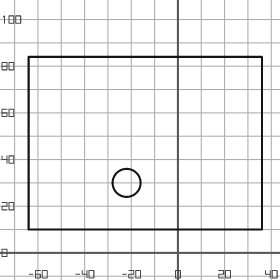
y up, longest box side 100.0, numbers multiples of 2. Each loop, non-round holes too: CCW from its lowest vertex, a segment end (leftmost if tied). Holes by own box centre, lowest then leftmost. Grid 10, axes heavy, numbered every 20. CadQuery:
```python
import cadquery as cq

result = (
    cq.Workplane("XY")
    .moveTo(-64.0, 10.0)
    .lineTo(36.0, 10.0)
    .lineTo(36.0, 84.0)
    .lineTo(-64.0, 84.0)
    .close()
    .moveTo(-22.0, 30.0)
    .circle(6.0)
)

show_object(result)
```